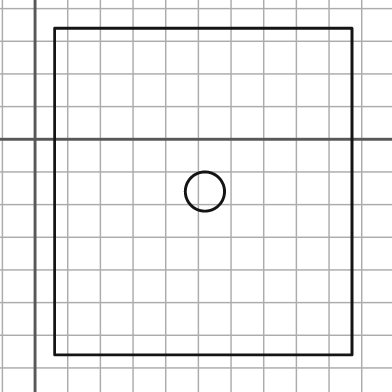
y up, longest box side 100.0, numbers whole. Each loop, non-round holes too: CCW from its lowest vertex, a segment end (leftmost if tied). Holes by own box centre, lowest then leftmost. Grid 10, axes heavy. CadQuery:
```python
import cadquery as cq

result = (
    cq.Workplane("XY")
    .moveTo(6.0, -66.0)
    .lineTo(97.0, -66.0)
    .lineTo(97.0, 34.0)
    .lineTo(6.0, 34.0)
    .close()
    .moveTo(52.0, -16.0)
    .circle(6.0)
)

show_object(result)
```